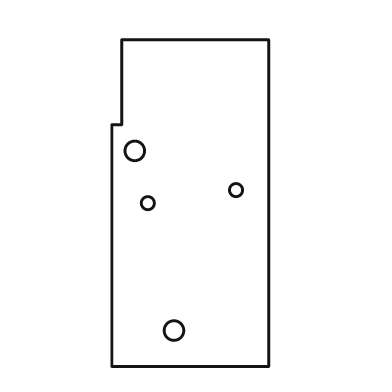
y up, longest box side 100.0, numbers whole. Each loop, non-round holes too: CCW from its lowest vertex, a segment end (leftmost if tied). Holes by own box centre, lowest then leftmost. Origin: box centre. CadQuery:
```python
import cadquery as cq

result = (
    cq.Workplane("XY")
    .moveTo(-24.0, -50.0)
    .lineTo(24.0, -50.0)
    .lineTo(24.0, 50.0)
    .lineTo(-21.0, 50.0)
    .lineTo(-21.0, 24.0)
    .lineTo(-24.0, 24.0)
    .close()
    .moveTo(-5.0, -39.0)
    .circle(3.0)
    .moveTo(-13.0, 0.0)
    .circle(2.0)
    .moveTo(14.0, 4.0)
    .circle(2.0)
    .moveTo(-17.0, 16.0)
    .circle(3.0)
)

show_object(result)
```